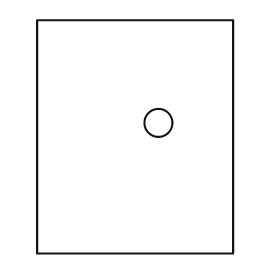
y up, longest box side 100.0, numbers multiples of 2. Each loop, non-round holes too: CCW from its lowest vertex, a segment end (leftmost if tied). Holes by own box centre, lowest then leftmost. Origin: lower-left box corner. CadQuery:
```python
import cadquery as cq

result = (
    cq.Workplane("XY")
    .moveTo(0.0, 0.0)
    .lineTo(84.0, 0.0)
    .lineTo(84.0, 100.0)
    .lineTo(0.0, 100.0)
    .close()
    .moveTo(52.0, 56.0)
    .circle(6.0)
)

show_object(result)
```